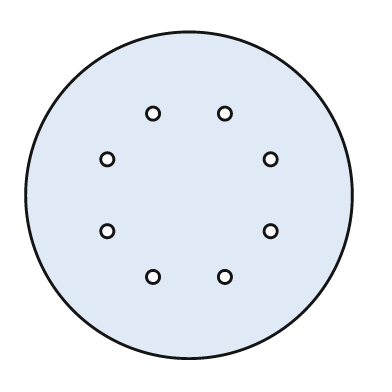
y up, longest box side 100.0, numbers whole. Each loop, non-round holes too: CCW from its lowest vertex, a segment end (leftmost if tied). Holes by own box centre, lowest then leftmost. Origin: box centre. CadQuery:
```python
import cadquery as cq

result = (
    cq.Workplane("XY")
    .moveTo(0.0, 0.0)
    .circle(50.0)
    .moveTo(-11.0, -25.0)
    .circle(2.0)
    .moveTo(11.0, -25.0)
    .circle(2.0)
    .moveTo(-25.0, -11.0)
    .circle(2.0)
    .moveTo(25.0, -11.0)
    .circle(2.0)
    .moveTo(-25.0, 11.0)
    .circle(2.0)
    .moveTo(25.0, 11.0)
    .circle(2.0)
    .moveTo(-11.0, 25.0)
    .circle(2.0)
    .moveTo(11.0, 25.0)
    .circle(2.0)
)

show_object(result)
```